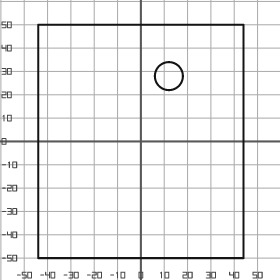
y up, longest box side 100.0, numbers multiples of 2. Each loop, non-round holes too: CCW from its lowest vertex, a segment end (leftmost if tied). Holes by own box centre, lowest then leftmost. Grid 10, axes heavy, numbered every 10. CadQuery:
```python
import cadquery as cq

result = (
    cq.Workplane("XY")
    .moveTo(-44.0, -50.0)
    .lineTo(44.0, -50.0)
    .lineTo(44.0, 50.0)
    .lineTo(-44.0, 50.0)
    .close()
    .moveTo(12.0, 28.0)
    .circle(6.0)
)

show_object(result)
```